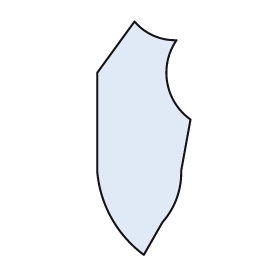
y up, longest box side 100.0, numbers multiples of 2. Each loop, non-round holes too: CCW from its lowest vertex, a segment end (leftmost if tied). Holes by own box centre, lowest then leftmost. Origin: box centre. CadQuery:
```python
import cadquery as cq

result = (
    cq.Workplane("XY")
    .moveTo(0.0, -50.0)
    .lineTo(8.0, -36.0)
    .threePointArc((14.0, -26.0), (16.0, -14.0))
    .lineTo(20.0, 8.0)
    .threePointArc((10.0, 24.0), (14.0, 42.0))
    .threePointArc((4.0, 44.0), (-4.0, 50.0))
    .lineTo(-20.0, 28.0)
    .lineTo(-20.0, -14.0)
    .threePointArc((-14.0, -34.0), (0.0, -50.0))
    .close()
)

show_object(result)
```